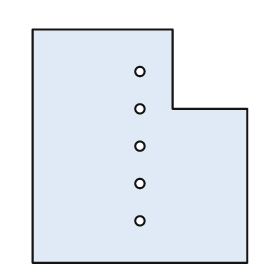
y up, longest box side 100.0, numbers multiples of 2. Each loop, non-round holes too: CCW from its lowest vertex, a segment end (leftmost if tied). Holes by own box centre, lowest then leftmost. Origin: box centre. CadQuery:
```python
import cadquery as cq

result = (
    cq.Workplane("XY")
    .moveTo(-46.0, -50.0)
    .lineTo(46.0, -50.0)
    .lineTo(46.0, 16.0)
    .lineTo(14.0, 16.0)
    .lineTo(14.0, 50.0)
    .lineTo(-46.0, 50.0)
    .close()
    .moveTo(0.0, -32.0)
    .circle(2.0)
    .moveTo(0.0, -16.0)
    .circle(2.0)
    .moveTo(0.0, 0.0)
    .circle(2.0)
    .moveTo(0.0, 16.0)
    .circle(2.0)
    .moveTo(0.0, 32.0)
    .circle(2.0)
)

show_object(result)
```